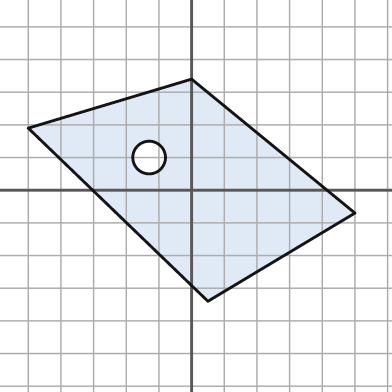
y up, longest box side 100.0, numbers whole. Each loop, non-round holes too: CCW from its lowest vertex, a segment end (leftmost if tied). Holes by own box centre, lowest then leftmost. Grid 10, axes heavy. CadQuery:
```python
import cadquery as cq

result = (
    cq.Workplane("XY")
    .moveTo(5.0, -34.0)
    .lineTo(50.0, -7.0)
    .lineTo(0.0, 34.0)
    .lineTo(-50.0, 19.0)
    .close()
    .moveTo(-13.0, 10.0)
    .circle(5.0)
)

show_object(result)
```